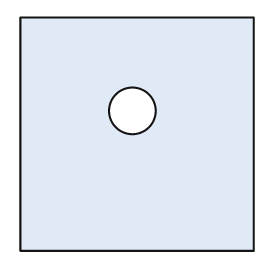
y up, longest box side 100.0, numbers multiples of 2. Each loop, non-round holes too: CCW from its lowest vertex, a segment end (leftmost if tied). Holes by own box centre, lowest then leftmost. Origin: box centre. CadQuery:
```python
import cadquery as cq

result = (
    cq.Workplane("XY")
    .moveTo(-50.0, -50.0)
    .lineTo(50.0, -50.0)
    .lineTo(50.0, 50.0)
    .lineTo(-50.0, 50.0)
    .close()
    .moveTo(-2.0, 10.0)
    .circle(10.0)
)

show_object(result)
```